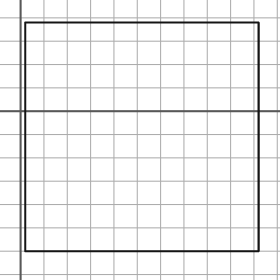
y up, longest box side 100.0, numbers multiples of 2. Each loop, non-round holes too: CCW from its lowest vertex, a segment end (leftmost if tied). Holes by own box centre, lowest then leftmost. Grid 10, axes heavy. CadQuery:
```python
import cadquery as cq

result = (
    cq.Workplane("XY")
    .moveTo(2.0, -60.0)
    .lineTo(102.0, -60.0)
    .lineTo(102.0, 38.0)
    .lineTo(2.0, 38.0)
    .close()
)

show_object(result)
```